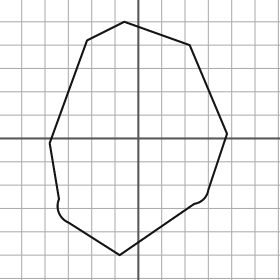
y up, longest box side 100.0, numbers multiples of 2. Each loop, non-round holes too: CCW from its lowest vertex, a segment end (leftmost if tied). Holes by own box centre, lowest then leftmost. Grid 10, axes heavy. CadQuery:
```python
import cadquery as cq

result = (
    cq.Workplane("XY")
    .moveTo(-8.0, -50.0)
    .lineTo(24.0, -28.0)
    .threePointArc((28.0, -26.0), (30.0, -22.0))
    .lineTo(38.0, 2.0)
    .lineTo(22.0, 40.0)
    .lineTo(-6.0, 50.0)
    .lineTo(-22.0, 42.0)
    .lineTo(-38.0, -2.0)
    .lineTo(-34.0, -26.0)
    .threePointArc((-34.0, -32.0), (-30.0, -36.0))
    .close()
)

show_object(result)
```